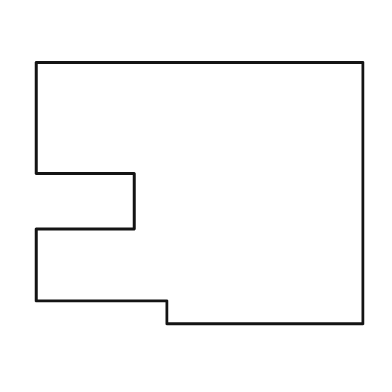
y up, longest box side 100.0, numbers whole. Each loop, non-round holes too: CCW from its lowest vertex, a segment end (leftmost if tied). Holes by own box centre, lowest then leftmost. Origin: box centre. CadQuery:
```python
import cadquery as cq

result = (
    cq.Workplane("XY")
    .moveTo(-10.0, -40.0)
    .lineTo(50.0, -40.0)
    .lineTo(50.0, 40.0)
    .lineTo(-50.0, 40.0)
    .lineTo(-50.0, 6.0)
    .lineTo(-20.0, 6.0)
    .lineTo(-20.0, -11.0)
    .lineTo(-50.0, -11.0)
    .lineTo(-50.0, -33.0)
    .lineTo(-10.0, -33.0)
    .close()
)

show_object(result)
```